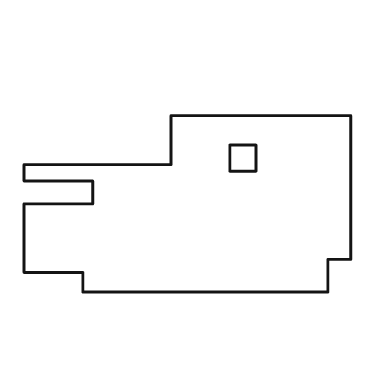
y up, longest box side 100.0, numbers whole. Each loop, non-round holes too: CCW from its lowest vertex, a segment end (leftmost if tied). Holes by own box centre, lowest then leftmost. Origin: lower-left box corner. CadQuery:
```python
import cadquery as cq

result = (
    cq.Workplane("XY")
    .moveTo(18.0, 0.0)
    .lineTo(93.0, 0.0)
    .lineTo(93.0, 10.0)
    .lineTo(100.0, 10.0)
    .lineTo(100.0, 54.0)
    .lineTo(45.0, 54.0)
    .lineTo(45.0, 39.0)
    .lineTo(0.0, 39.0)
    .lineTo(0.0, 34.0)
    .lineTo(21.0, 34.0)
    .lineTo(21.0, 27.0)
    .lineTo(0.0, 27.0)
    .lineTo(0.0, 6.0)
    .lineTo(18.0, 6.0)
    .close()
    .moveTo(63.0, 37.0)
    .lineTo(71.0, 37.0)
    .lineTo(71.0, 45.0)
    .lineTo(63.0, 45.0)
    .close()
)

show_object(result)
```